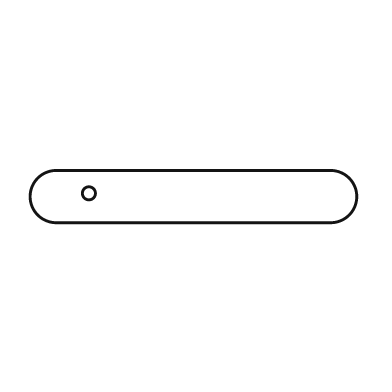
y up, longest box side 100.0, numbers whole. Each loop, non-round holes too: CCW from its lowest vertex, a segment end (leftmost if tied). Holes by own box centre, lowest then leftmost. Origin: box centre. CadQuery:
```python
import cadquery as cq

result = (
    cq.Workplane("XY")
    .moveTo(-42.0, -8.0)
    .lineTo(42.0, -8.0)
    .threePointArc((50.0, 0.0), (42.0, 8.0))
    .lineTo(-42.0, 8.0)
    .threePointArc((-50.0, 0.0), (-42.0, -8.0))
    .close()
    .moveTo(-32.0, 1.0)
    .circle(2.0)
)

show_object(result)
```